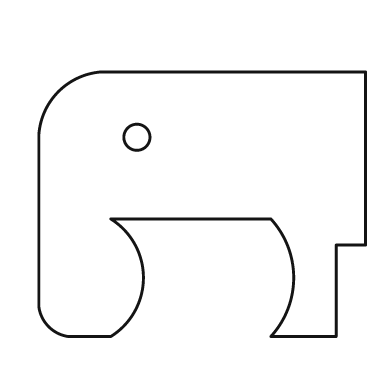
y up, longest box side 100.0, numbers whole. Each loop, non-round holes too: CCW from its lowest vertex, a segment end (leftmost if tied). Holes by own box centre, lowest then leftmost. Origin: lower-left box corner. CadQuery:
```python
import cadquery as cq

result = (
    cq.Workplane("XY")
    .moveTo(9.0, 0.0)
    .lineTo(22.0, 0.0)
    .threePointArc((32.0, 18.0), (22.0, 36.0))
    .lineTo(71.0, 36.0)
    .threePointArc((78.0, 18.0), (71.0, 0.0))
    .lineTo(91.0, 0.0)
    .lineTo(91.0, 28.0)
    .lineTo(100.0, 28.0)
    .lineTo(100.0, 81.0)
    .lineTo(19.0, 81.0)
    .threePointArc((6.0, 75.0), (0.0, 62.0))
    .lineTo(0.0, 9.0)
    .threePointArc((3.0, 3.0), (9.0, 0.0))
    .close()
    .moveTo(30.0, 61.0)
    .circle(4.0)
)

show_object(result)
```